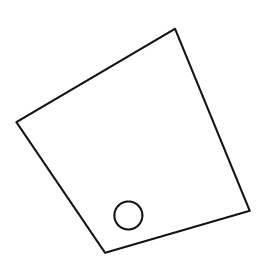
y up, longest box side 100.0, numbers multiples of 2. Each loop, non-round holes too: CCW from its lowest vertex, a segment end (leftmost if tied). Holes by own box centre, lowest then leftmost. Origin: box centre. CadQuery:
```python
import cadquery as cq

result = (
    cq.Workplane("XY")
    .moveTo(-12.0, -48.0)
    .lineTo(50.0, -30.0)
    .lineTo(18.0, 48.0)
    .lineTo(-50.0, 8.0)
    .close()
    .moveTo(-2.0, -32.0)
    .circle(6.0)
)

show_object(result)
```